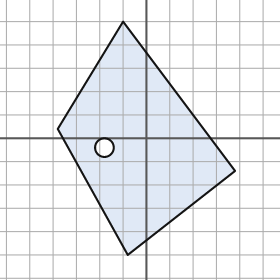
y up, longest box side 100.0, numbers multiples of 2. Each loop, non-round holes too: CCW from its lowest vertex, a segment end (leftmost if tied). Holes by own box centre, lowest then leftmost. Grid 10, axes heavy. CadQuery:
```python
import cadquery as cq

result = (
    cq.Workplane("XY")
    .moveTo(-8.0, -50.0)
    .lineTo(38.0, -14.0)
    .lineTo(-10.0, 50.0)
    .lineTo(-38.0, 4.0)
    .close()
    .moveTo(-18.0, -4.0)
    .circle(4.0)
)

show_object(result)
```